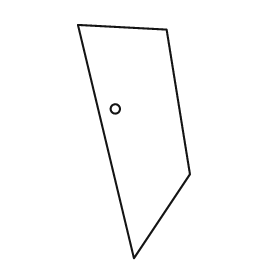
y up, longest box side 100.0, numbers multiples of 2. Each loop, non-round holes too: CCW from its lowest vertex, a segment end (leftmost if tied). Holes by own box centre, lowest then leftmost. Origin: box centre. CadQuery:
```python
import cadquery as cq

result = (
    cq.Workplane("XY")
    .moveTo(0.0, -50.0)
    .lineTo(24.0, -14.0)
    .lineTo(14.0, 48.0)
    .lineTo(-24.0, 50.0)
    .close()
    .moveTo(-8.0, 14.0)
    .circle(2.0)
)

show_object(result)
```